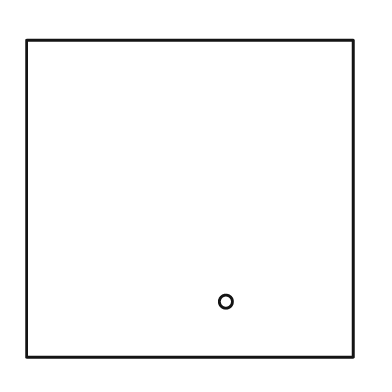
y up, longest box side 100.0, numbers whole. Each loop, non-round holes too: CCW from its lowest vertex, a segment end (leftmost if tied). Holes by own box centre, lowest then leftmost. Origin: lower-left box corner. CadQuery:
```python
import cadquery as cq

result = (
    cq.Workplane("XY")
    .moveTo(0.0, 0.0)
    .lineTo(100.0, 0.0)
    .lineTo(100.0, 97.0)
    .lineTo(0.0, 97.0)
    .close()
    .moveTo(61.0, 17.0)
    .circle(2.0)
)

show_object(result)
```